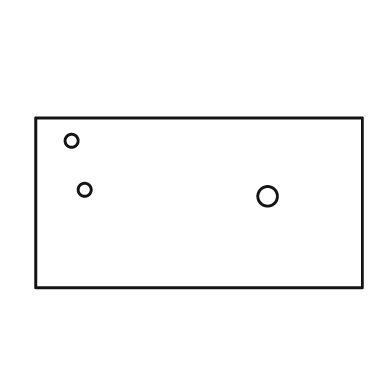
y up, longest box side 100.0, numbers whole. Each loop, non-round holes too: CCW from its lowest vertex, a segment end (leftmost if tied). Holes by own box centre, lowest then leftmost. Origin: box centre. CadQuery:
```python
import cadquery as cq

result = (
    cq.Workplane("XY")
    .moveTo(-50.0, -26.0)
    .lineTo(50.0, -26.0)
    .lineTo(50.0, 26.0)
    .lineTo(-50.0, 26.0)
    .close()
    .moveTo(21.0, 2.0)
    .circle(3.0)
    .moveTo(-35.0, 4.0)
    .circle(2.0)
    .moveTo(-39.0, 19.0)
    .circle(2.0)
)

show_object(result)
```